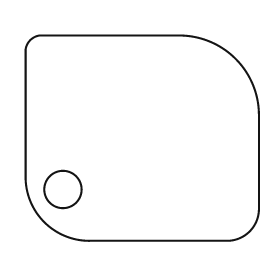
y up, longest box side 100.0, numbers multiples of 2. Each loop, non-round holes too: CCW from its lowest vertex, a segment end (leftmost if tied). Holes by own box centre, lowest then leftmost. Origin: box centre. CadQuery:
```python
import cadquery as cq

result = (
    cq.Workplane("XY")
    .moveTo(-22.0, -44.0)
    .lineTo(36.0, -44.0)
    .threePointArc((46.0, -40.0), (50.0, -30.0))
    .lineTo(50.0, 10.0)
    .threePointArc((40.0, 34.0), (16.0, 44.0))
    .lineTo(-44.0, 44.0)
    .threePointArc((-48.0, 42.0), (-50.0, 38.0))
    .lineTo(-50.0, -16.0)
    .threePointArc((-42.0, -36.0), (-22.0, -44.0))
    .close()
    .moveTo(-34.0, -22.0)
    .circle(8.0)
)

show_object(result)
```